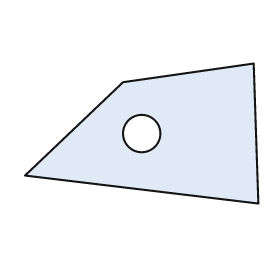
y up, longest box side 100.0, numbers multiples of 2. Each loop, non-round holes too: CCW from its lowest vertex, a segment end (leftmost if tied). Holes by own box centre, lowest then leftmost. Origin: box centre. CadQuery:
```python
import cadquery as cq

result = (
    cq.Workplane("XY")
    .moveTo(50.0, -30.0)
    .lineTo(48.0, 30.0)
    .lineTo(-8.0, 22.0)
    .lineTo(-50.0, -18.0)
    .close()
    .moveTo(0.0, 0.0)
    .circle(8.0)
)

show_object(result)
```